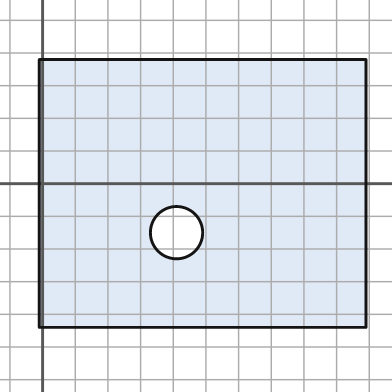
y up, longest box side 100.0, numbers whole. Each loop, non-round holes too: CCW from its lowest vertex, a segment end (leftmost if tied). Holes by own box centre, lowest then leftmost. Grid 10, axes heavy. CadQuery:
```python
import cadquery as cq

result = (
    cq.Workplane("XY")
    .moveTo(-1.0, -44.0)
    .lineTo(99.0, -44.0)
    .lineTo(99.0, 38.0)
    .lineTo(-1.0, 38.0)
    .close()
    .moveTo(41.0, -15.0)
    .circle(8.0)
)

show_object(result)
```